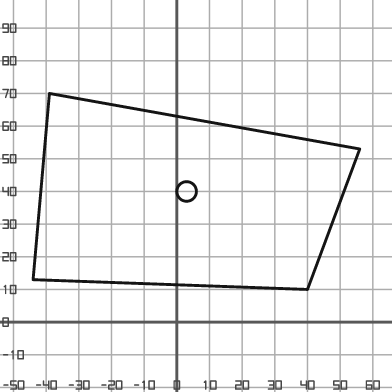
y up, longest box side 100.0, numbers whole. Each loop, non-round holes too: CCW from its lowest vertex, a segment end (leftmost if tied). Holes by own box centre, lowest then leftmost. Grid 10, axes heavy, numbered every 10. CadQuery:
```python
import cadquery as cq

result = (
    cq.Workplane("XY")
    .moveTo(40.0, 10.0)
    .lineTo(56.0, 53.0)
    .lineTo(-39.0, 70.0)
    .lineTo(-44.0, 13.0)
    .close()
    .moveTo(3.0, 40.0)
    .circle(3.0)
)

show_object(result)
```